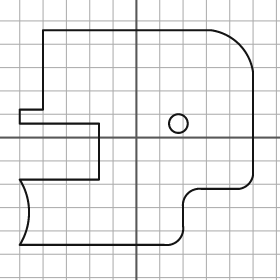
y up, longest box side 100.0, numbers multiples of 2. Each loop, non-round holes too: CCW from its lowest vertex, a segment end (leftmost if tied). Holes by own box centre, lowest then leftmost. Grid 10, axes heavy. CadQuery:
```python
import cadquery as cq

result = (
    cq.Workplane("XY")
    .moveTo(-50.0, -46.0)
    .lineTo(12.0, -46.0)
    .threePointArc((18.0, -44.0), (20.0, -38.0))
    .lineTo(20.0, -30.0)
    .threePointArc((22.0, -24.0), (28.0, -22.0))
    .lineTo(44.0, -22.0)
    .threePointArc((48.0, -20.0), (50.0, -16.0))
    .lineTo(50.0, 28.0)
    .threePointArc((44.0, 40.0), (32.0, 46.0))
    .lineTo(-40.0, 46.0)
    .lineTo(-40.0, 12.0)
    .lineTo(-50.0, 12.0)
    .lineTo(-50.0, 6.0)
    .lineTo(-16.0, 6.0)
    .lineTo(-16.0, -18.0)
    .lineTo(-50.0, -18.0)
    .threePointArc((-46.0, -32.0), (-50.0, -46.0))
    .close()
    .moveTo(18.0, 6.0)
    .circle(4.0)
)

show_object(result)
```